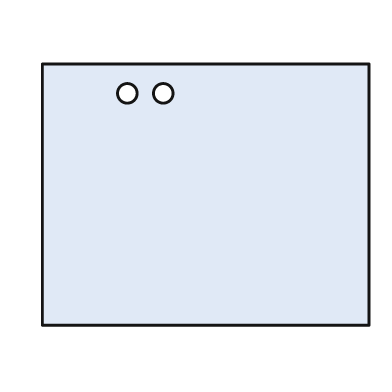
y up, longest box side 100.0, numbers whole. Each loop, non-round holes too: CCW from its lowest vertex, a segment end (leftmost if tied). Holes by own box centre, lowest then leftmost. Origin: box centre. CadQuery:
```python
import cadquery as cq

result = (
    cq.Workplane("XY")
    .moveTo(-50.0, -40.0)
    .lineTo(50.0, -40.0)
    .lineTo(50.0, 40.0)
    .lineTo(-50.0, 40.0)
    .close()
    .moveTo(-24.0, 31.0)
    .circle(3.0)
    .moveTo(-13.0, 31.0)
    .circle(3.0)
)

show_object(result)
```